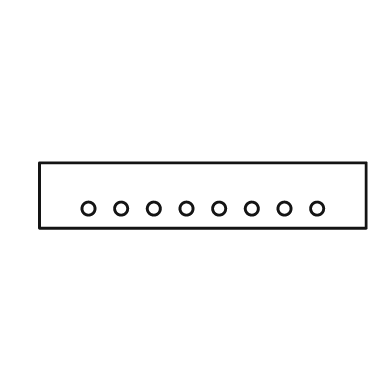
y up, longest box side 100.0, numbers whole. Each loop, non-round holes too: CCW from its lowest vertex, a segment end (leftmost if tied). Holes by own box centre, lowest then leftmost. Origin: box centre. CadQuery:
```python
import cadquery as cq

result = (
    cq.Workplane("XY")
    .moveTo(-50.0, -10.0)
    .lineTo(50.0, -10.0)
    .lineTo(50.0, 10.0)
    .lineTo(-50.0, 10.0)
    .close()
    .moveTo(-35.0, -4.0)
    .circle(2.0)
    .moveTo(-25.0, -4.0)
    .circle(2.0)
    .moveTo(-15.0, -4.0)
    .circle(2.0)
    .moveTo(-5.0, -4.0)
    .circle(2.0)
    .moveTo(5.0, -4.0)
    .circle(2.0)
    .moveTo(15.0, -4.0)
    .circle(2.0)
    .moveTo(25.0, -4.0)
    .circle(2.0)
    .moveTo(35.0, -4.0)
    .circle(2.0)
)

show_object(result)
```